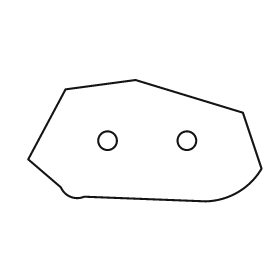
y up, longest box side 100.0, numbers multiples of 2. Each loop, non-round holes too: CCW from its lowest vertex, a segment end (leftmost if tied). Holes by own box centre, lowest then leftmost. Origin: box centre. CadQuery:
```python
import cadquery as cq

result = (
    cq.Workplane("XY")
    .moveTo(26.0, -26.0)
    .threePointArc((40.0, -22.0), (50.0, -12.0))
    .lineTo(42.0, 12.0)
    .lineTo(-4.0, 26.0)
    .lineTo(-34.0, 22.0)
    .lineTo(-50.0, -8.0)
    .lineTo(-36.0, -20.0)
    .threePointArc((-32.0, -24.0), (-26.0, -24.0))
    .close()
    .moveTo(-16.0, 0.0)
    .circle(4.0)
    .moveTo(18.0, 0.0)
    .circle(4.0)
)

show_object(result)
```